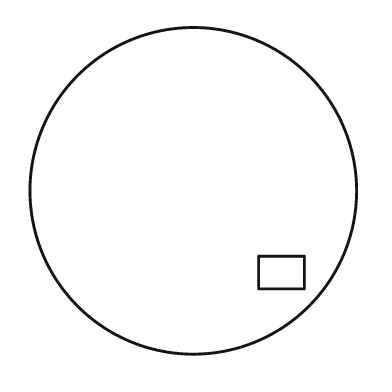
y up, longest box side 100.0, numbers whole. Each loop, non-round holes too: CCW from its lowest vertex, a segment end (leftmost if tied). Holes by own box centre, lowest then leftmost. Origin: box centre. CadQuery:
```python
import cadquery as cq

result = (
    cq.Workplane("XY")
    .moveTo(0.0, 0.0)
    .circle(50.0)
    .moveTo(20.0, -30.0)
    .lineTo(34.0, -30.0)
    .lineTo(34.0, -20.0)
    .lineTo(20.0, -20.0)
    .close()
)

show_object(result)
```